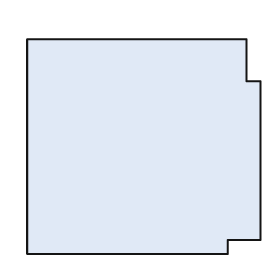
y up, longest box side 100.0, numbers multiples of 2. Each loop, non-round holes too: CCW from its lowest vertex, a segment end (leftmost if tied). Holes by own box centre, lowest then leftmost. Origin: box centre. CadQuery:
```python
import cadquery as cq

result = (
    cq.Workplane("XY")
    .moveTo(-50.0, -46.0)
    .lineTo(36.0, -46.0)
    .lineTo(36.0, -40.0)
    .lineTo(50.0, -40.0)
    .lineTo(50.0, 28.0)
    .lineTo(44.0, 28.0)
    .lineTo(44.0, 46.0)
    .lineTo(-50.0, 46.0)
    .close()
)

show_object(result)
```